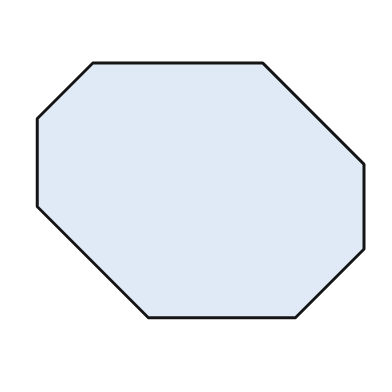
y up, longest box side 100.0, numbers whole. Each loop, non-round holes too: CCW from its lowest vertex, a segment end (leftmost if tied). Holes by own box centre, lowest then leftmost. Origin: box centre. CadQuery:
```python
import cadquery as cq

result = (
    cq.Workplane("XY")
    .moveTo(-16.0, -39.0)
    .lineTo(29.0, -39.0)
    .lineTo(50.0, -18.0)
    .lineTo(50.0, 8.0)
    .lineTo(19.0, 39.0)
    .lineTo(-33.0, 39.0)
    .lineTo(-50.0, 22.0)
    .lineTo(-50.0, -5.0)
    .close()
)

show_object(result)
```